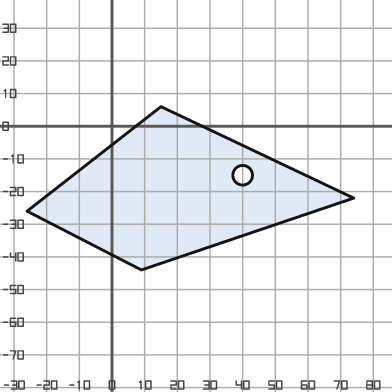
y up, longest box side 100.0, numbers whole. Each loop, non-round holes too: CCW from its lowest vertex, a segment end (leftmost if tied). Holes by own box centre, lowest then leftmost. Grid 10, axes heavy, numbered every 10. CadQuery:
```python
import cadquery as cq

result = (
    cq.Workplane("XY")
    .moveTo(9.0, -44.0)
    .lineTo(74.0, -22.0)
    .lineTo(15.0, 6.0)
    .lineTo(-26.0, -26.0)
    .close()
    .moveTo(40.0, -15.0)
    .circle(3.0)
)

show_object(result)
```